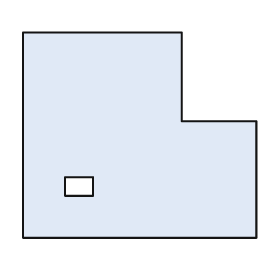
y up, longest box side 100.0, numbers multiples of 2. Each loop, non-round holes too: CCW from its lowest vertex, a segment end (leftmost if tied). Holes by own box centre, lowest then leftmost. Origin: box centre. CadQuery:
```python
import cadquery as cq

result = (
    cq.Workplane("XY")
    .moveTo(-50.0, -44.0)
    .lineTo(50.0, -44.0)
    .lineTo(50.0, 6.0)
    .lineTo(18.0, 6.0)
    .lineTo(18.0, 44.0)
    .lineTo(-50.0, 44.0)
    .close()
    .moveTo(-32.0, -26.0)
    .lineTo(-20.0, -26.0)
    .lineTo(-20.0, -18.0)
    .lineTo(-32.0, -18.0)
    .close()
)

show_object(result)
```